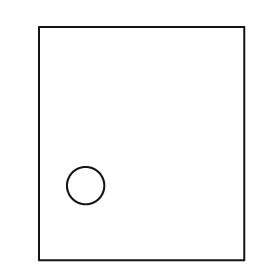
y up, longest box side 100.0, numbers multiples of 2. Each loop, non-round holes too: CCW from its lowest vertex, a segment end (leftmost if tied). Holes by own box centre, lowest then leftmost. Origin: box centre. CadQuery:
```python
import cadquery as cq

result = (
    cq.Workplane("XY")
    .moveTo(-44.0, -50.0)
    .lineTo(44.0, -50.0)
    .lineTo(44.0, 50.0)
    .lineTo(-44.0, 50.0)
    .close()
    .moveTo(-24.0, -18.0)
    .circle(8.0)
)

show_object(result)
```